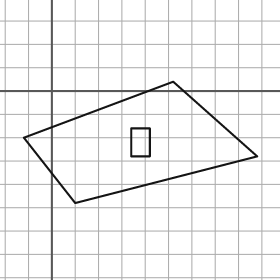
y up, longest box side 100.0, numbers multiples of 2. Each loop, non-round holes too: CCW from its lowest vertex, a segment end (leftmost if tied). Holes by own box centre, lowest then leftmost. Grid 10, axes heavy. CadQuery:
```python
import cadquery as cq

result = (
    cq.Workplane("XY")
    .moveTo(10.0, -48.0)
    .lineTo(88.0, -28.0)
    .lineTo(52.0, 4.0)
    .lineTo(-12.0, -20.0)
    .close()
    .moveTo(34.0, -28.0)
    .lineTo(42.0, -28.0)
    .lineTo(42.0, -16.0)
    .lineTo(34.0, -16.0)
    .close()
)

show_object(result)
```